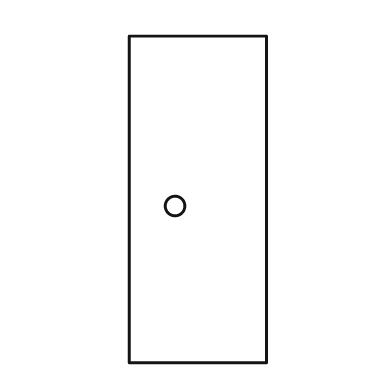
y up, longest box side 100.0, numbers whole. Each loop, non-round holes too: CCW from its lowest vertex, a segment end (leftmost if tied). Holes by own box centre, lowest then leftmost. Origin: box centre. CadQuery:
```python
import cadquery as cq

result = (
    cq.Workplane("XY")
    .moveTo(-21.0, -50.0)
    .lineTo(21.0, -50.0)
    .lineTo(21.0, 50.0)
    .lineTo(-21.0, 50.0)
    .close()
    .moveTo(-7.0, -2.0)
    .circle(3.0)
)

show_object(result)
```